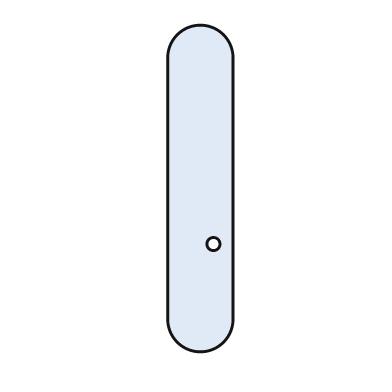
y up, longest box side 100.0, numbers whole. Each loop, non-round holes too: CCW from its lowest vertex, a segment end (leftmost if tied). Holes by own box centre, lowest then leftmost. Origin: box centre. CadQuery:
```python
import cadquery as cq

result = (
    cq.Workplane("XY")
    .moveTo(-10.0, -40.0)
    .threePointArc((0.0, -50.0), (10.0, -40.0))
    .lineTo(10.0, 40.0)
    .threePointArc((0.0, 50.0), (-10.0, 40.0))
    .close()
    .moveTo(4.0, -17.0)
    .circle(2.0)
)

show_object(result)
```